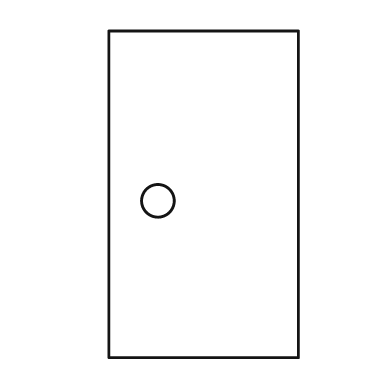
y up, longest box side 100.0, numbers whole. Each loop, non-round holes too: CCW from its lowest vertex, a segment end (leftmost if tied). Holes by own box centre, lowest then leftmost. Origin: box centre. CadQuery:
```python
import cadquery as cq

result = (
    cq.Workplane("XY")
    .moveTo(-29.0, -50.0)
    .lineTo(29.0, -50.0)
    .lineTo(29.0, 50.0)
    .lineTo(-29.0, 50.0)
    .close()
    .moveTo(-14.0, -2.0)
    .circle(5.0)
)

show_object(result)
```